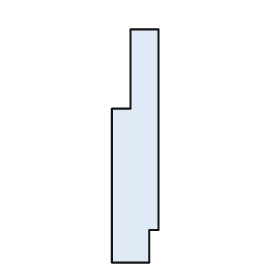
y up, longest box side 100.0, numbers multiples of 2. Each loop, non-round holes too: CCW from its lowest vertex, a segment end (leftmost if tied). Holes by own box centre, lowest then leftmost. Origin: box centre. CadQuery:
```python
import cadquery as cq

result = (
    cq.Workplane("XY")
    .moveTo(-10.0, -50.0)
    .lineTo(6.0, -50.0)
    .lineTo(6.0, -36.0)
    .lineTo(10.0, -36.0)
    .lineTo(10.0, 50.0)
    .lineTo(-2.0, 50.0)
    .lineTo(-2.0, 16.0)
    .lineTo(-10.0, 16.0)
    .close()
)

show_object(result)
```